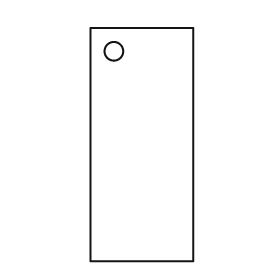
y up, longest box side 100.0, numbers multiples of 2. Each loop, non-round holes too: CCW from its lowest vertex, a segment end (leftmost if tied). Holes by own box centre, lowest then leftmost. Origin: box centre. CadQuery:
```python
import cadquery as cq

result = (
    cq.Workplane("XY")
    .moveTo(-22.0, -50.0)
    .lineTo(22.0, -50.0)
    .lineTo(22.0, 50.0)
    .lineTo(-22.0, 50.0)
    .close()
    .moveTo(-12.0, 40.0)
    .circle(4.0)
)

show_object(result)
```